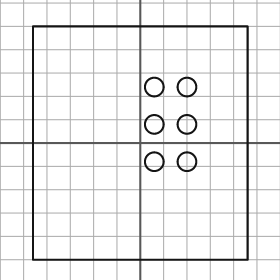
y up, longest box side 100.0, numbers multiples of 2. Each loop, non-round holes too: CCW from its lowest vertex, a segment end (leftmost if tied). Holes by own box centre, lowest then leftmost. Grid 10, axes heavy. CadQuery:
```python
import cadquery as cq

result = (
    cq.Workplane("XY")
    .moveTo(-46.0, -50.0)
    .lineTo(46.0, -50.0)
    .lineTo(46.0, 50.0)
    .lineTo(-46.0, 50.0)
    .close()
    .moveTo(6.0, -8.0)
    .circle(4.0)
    .moveTo(20.0, -8.0)
    .circle(4.0)
    .moveTo(6.0, 8.0)
    .circle(4.0)
    .moveTo(20.0, 8.0)
    .circle(4.0)
    .moveTo(6.0, 24.0)
    .circle(4.0)
    .moveTo(20.0, 24.0)
    .circle(4.0)
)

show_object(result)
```